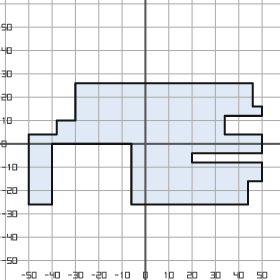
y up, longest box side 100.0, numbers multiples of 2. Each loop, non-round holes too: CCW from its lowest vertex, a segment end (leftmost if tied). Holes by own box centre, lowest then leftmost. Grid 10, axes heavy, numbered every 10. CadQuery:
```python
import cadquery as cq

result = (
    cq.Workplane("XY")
    .moveTo(-50.0, -26.0)
    .lineTo(-40.0, -26.0)
    .lineTo(-40.0, 0.0)
    .lineTo(-6.0, 0.0)
    .lineTo(-6.0, -26.0)
    .lineTo(44.0, -26.0)
    .lineTo(44.0, -16.0)
    .lineTo(50.0, -16.0)
    .lineTo(50.0, -8.0)
    .lineTo(20.0, -8.0)
    .lineTo(20.0, -4.0)
    .lineTo(50.0, -4.0)
    .lineTo(50.0, 4.0)
    .lineTo(34.0, 4.0)
    .lineTo(34.0, 12.0)
    .lineTo(50.0, 12.0)
    .lineTo(50.0, 16.0)
    .lineTo(46.0, 16.0)
    .lineTo(46.0, 26.0)
    .lineTo(-30.0, 26.0)
    .lineTo(-30.0, 10.0)
    .lineTo(-38.0, 10.0)
    .lineTo(-38.0, 4.0)
    .lineTo(-50.0, 4.0)
    .close()
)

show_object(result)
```